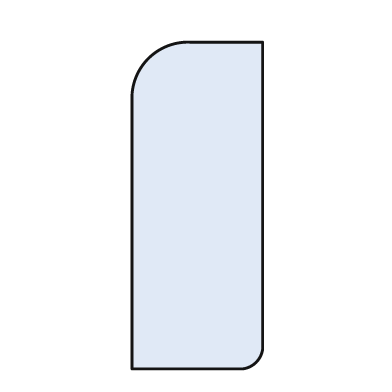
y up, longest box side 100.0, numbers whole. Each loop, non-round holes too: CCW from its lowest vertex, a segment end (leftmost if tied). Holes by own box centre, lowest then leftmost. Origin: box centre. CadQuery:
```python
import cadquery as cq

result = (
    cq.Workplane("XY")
    .moveTo(-20.0, -50.0)
    .lineTo(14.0, -50.0)
    .threePointArc((18.0, -48.0), (20.0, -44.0))
    .lineTo(20.0, 50.0)
    .lineTo(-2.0, 50.0)
    .threePointArc((-15.0, 45.0), (-20.0, 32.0))
    .close()
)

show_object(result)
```